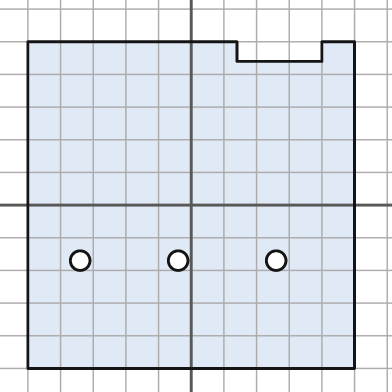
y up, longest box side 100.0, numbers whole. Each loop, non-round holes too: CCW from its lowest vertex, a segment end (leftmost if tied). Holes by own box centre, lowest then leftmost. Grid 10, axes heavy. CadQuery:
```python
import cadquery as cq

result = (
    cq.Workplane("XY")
    .moveTo(-50.0, -50.0)
    .lineTo(50.0, -50.0)
    .lineTo(50.0, 50.0)
    .lineTo(40.0, 50.0)
    .lineTo(40.0, 44.0)
    .lineTo(14.0, 44.0)
    .lineTo(14.0, 50.0)
    .lineTo(-50.0, 50.0)
    .close()
    .moveTo(-34.0, -17.0)
    .circle(3.0)
    .moveTo(-4.0, -17.0)
    .circle(3.0)
    .moveTo(26.0, -17.0)
    .circle(3.0)
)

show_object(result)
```